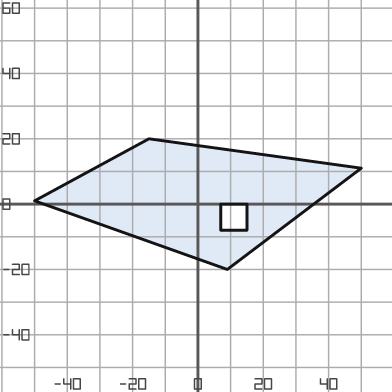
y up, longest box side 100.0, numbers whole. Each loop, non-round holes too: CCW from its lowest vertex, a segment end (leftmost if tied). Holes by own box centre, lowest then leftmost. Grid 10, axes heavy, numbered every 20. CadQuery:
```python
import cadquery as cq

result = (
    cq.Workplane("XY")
    .moveTo(9.0, -20.0)
    .lineTo(50.0, 11.0)
    .lineTo(-15.0, 20.0)
    .lineTo(-50.0, 1.0)
    .close()
    .moveTo(7.0, -8.0)
    .lineTo(15.0, -8.0)
    .lineTo(15.0, 0.0)
    .lineTo(7.0, 0.0)
    .close()
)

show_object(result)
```